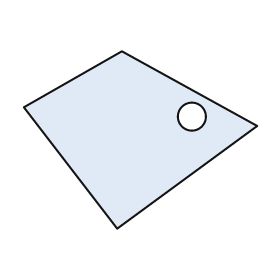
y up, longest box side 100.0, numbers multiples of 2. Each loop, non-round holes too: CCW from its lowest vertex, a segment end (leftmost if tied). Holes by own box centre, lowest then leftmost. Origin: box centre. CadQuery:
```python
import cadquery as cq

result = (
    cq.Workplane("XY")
    .moveTo(-10.0, -38.0)
    .lineTo(50.0, 6.0)
    .lineTo(-8.0, 38.0)
    .lineTo(-50.0, 14.0)
    .close()
    .moveTo(22.0, 10.0)
    .circle(6.0)
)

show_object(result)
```